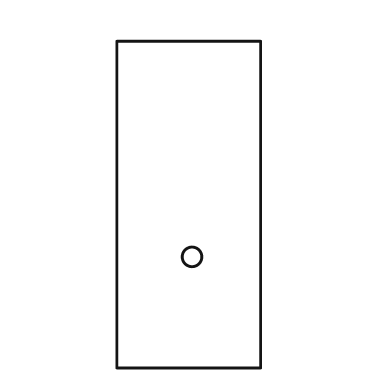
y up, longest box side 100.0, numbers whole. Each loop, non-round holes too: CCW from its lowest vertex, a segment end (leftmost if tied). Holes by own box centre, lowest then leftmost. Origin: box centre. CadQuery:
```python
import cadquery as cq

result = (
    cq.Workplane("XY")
    .moveTo(-22.0, -50.0)
    .lineTo(22.0, -50.0)
    .lineTo(22.0, 50.0)
    .lineTo(-22.0, 50.0)
    .close()
    .moveTo(1.0, -16.0)
    .circle(3.0)
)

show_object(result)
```